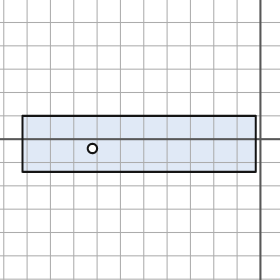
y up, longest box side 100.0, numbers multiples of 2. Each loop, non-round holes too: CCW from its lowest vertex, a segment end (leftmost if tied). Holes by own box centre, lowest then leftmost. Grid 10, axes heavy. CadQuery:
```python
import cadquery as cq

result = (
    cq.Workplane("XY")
    .moveTo(-102.0, -14.0)
    .lineTo(-2.0, -14.0)
    .lineTo(-2.0, 10.0)
    .lineTo(-102.0, 10.0)
    .close()
    .moveTo(-72.0, -4.0)
    .circle(2.0)
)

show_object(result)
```